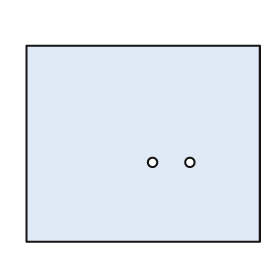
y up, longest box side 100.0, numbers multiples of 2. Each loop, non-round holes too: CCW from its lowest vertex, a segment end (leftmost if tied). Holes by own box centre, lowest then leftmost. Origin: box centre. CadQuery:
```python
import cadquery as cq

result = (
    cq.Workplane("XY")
    .moveTo(-50.0, -42.0)
    .lineTo(50.0, -42.0)
    .lineTo(50.0, 42.0)
    .lineTo(-50.0, 42.0)
    .close()
    .moveTo(4.0, -8.0)
    .circle(2.0)
    .moveTo(20.0, -8.0)
    .circle(2.0)
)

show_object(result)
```